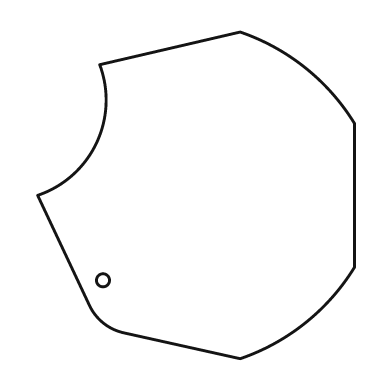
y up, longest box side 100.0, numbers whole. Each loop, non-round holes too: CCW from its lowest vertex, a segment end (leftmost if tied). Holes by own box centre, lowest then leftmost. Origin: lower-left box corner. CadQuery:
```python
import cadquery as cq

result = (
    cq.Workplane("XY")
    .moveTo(62.0, 0.0)
    .threePointArc((82.0, 11.0), (97.0, 28.0))
    .lineTo(97.0, 72.0)
    .threePointArc((82.0, 89.0), (62.0, 100.0))
    .lineTo(19.0, 90.0)
    .threePointArc((18.0, 66.0), (0.0, 50.0))
    .lineTo(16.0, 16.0)
    .threePointArc((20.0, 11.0), (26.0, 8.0))
    .close()
    .moveTo(20.0, 24.0)
    .circle(2.0)
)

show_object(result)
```